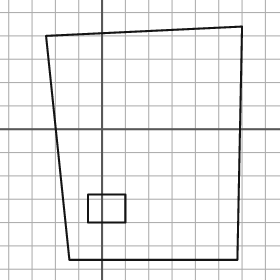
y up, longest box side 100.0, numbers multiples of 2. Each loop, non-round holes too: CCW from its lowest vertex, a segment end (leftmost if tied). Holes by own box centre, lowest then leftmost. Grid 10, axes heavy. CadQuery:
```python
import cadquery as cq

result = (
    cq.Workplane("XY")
    .moveTo(-14.0, -56.0)
    .lineTo(58.0, -56.0)
    .lineTo(60.0, 44.0)
    .lineTo(-24.0, 40.0)
    .close()
    .moveTo(-6.0, -40.0)
    .lineTo(10.0, -40.0)
    .lineTo(10.0, -28.0)
    .lineTo(-6.0, -28.0)
    .close()
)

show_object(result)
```